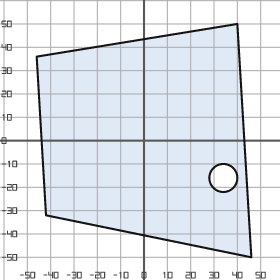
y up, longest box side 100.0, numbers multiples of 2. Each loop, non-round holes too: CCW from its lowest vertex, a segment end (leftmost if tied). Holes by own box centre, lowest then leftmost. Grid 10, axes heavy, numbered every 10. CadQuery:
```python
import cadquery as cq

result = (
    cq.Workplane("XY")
    .moveTo(46.0, -50.0)
    .lineTo(40.0, 50.0)
    .lineTo(-46.0, 36.0)
    .lineTo(-42.0, -32.0)
    .close()
    .moveTo(34.0, -16.0)
    .circle(6.0)
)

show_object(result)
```